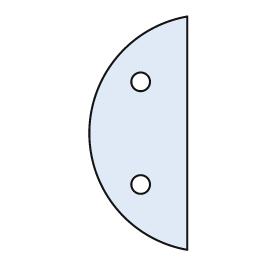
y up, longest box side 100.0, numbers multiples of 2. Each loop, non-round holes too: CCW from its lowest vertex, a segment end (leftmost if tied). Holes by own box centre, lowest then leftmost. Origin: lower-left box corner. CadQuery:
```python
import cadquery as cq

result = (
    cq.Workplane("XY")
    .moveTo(42.0, 0.0)
    .lineTo(42.0, 100.0)
    .threePointArc((0.0, 50.0), (42.0, 0.0))
    .close()
    .moveTo(22.0, 28.0)
    .circle(4.0)
    .moveTo(22.0, 72.0)
    .circle(4.0)
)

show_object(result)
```